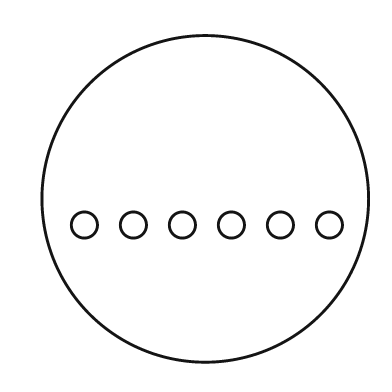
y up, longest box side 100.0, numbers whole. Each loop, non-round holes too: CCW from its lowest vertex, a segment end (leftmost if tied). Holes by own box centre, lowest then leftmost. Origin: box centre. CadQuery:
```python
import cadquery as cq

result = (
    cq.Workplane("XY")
    .moveTo(0.0, 0.0)
    .circle(50.0)
    .moveTo(-37.0, -8.0)
    .circle(4.0)
    .moveTo(-22.0, -8.0)
    .circle(4.0)
    .moveTo(-7.0, -8.0)
    .circle(4.0)
    .moveTo(8.0, -8.0)
    .circle(4.0)
    .moveTo(23.0, -8.0)
    .circle(4.0)
    .moveTo(38.0, -8.0)
    .circle(4.0)
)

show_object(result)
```